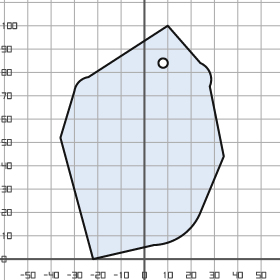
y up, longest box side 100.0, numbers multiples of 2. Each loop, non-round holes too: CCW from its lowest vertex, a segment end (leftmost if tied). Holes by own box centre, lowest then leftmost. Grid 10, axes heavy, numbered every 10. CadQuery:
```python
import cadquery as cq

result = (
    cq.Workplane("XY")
    .moveTo(-22.0, 0.0)
    .lineTo(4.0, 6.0)
    .threePointArc((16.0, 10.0), (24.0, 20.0))
    .lineTo(34.0, 44.0)
    .lineTo(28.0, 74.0)
    .threePointArc((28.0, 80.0), (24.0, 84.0))
    .lineTo(10.0, 100.0)
    .lineTo(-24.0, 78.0)
    .threePointArc((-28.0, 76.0), (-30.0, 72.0))
    .lineTo(-36.0, 52.0)
    .close()
    .moveTo(8.0, 84.0)
    .circle(2.0)
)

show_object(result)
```